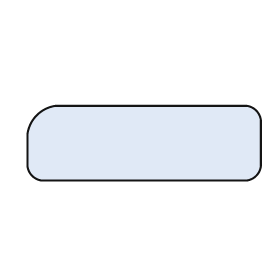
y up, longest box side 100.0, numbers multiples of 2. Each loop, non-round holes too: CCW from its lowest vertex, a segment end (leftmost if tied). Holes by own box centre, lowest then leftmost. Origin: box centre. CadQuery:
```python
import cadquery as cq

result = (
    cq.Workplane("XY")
    .moveTo(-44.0, -16.0)
    .lineTo(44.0, -16.0)
    .threePointArc((48.0, -14.0), (50.0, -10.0))
    .lineTo(50.0, 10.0)
    .threePointArc((48.0, 14.0), (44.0, 16.0))
    .lineTo(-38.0, 16.0)
    .threePointArc((-46.0, 12.0), (-50.0, 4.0))
    .lineTo(-50.0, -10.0)
    .threePointArc((-48.0, -14.0), (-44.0, -16.0))
    .close()
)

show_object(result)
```